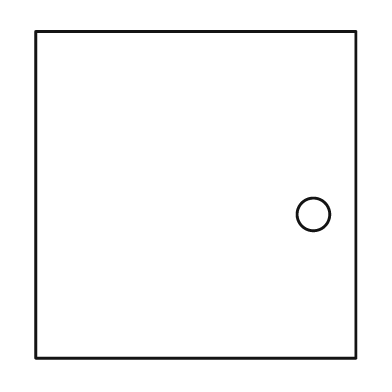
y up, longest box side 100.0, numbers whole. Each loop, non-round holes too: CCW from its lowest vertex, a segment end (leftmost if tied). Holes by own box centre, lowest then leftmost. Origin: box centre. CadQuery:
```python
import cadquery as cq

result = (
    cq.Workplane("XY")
    .moveTo(-49.0, -50.0)
    .lineTo(49.0, -50.0)
    .lineTo(49.0, 50.0)
    .lineTo(-49.0, 50.0)
    .close()
    .moveTo(36.0, -6.0)
    .circle(5.0)
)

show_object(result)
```